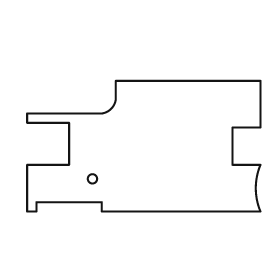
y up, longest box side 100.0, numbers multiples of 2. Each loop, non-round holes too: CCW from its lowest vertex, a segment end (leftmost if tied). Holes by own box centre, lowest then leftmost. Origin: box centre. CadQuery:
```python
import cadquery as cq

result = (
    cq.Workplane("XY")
    .moveTo(-50.0, -28.0)
    .lineTo(-46.0, -28.0)
    .lineTo(-46.0, -24.0)
    .lineTo(-18.0, -24.0)
    .lineTo(-18.0, -28.0)
    .lineTo(50.0, -28.0)
    .threePointArc((48.0, -18.0), (50.0, -8.0))
    .lineTo(38.0, -8.0)
    .lineTo(38.0, 8.0)
    .lineTo(50.0, 8.0)
    .lineTo(50.0, 28.0)
    .lineTo(-12.0, 28.0)
    .lineTo(-12.0, 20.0)
    .threePointArc((-14.0, 16.0), (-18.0, 14.0))
    .lineTo(-50.0, 14.0)
    .lineTo(-50.0, 10.0)
    .lineTo(-32.0, 10.0)
    .lineTo(-32.0, -8.0)
    .lineTo(-50.0, -8.0)
    .close()
    .moveTo(-22.0, -14.0)
    .circle(2.0)
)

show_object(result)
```